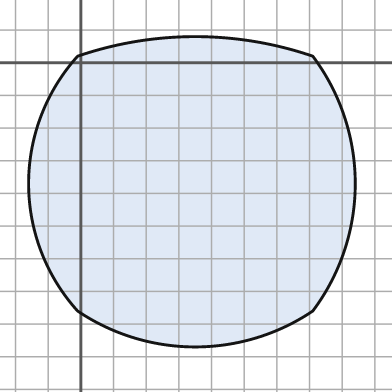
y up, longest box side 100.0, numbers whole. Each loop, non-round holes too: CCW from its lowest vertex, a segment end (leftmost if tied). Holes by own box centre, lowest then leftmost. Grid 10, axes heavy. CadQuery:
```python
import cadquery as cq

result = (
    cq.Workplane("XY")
    .moveTo(-1.0, -76.0)
    .threePointArc((35.0, -87.0), (71.0, -76.0))
    .threePointArc((84.0, -37.0), (71.0, 2.0))
    .threePointArc((35.0, 8.0), (-1.0, 2.0))
    .threePointArc((-16.0, -37.0), (-1.0, -76.0))
    .close()
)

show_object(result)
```